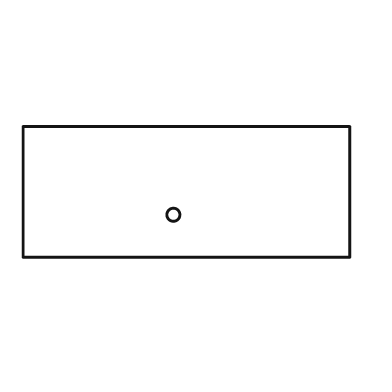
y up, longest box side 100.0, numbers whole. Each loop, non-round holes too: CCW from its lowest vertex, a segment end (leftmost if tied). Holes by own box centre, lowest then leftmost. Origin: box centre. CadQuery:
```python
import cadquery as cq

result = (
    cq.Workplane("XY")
    .moveTo(-50.0, -20.0)
    .lineTo(50.0, -20.0)
    .lineTo(50.0, 20.0)
    .lineTo(-50.0, 20.0)
    .close()
    .moveTo(-4.0, -7.0)
    .circle(2.0)
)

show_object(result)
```